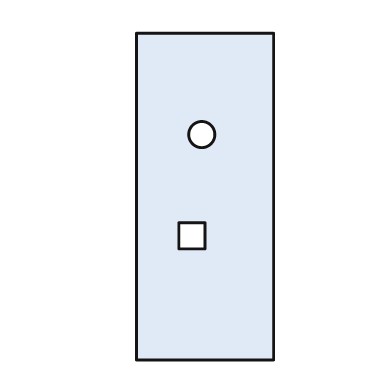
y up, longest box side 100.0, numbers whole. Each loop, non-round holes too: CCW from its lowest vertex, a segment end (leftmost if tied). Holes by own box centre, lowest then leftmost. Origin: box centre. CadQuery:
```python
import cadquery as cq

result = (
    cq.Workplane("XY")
    .moveTo(-21.0, -50.0)
    .lineTo(21.0, -50.0)
    .lineTo(21.0, 50.0)
    .lineTo(-21.0, 50.0)
    .close()
    .moveTo(-8.0, -16.0)
    .lineTo(0.0, -16.0)
    .lineTo(0.0, -8.0)
    .lineTo(-8.0, -8.0)
    .close()
    .moveTo(-1.0, 19.0)
    .circle(4.0)
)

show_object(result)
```